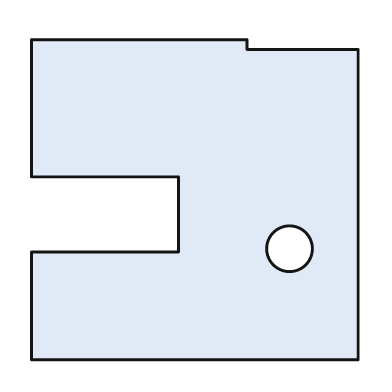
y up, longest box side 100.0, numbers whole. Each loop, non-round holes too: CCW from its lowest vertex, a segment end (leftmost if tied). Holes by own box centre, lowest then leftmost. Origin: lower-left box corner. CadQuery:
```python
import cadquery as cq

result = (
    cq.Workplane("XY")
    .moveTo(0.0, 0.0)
    .lineTo(100.0, 0.0)
    .lineTo(100.0, 95.0)
    .lineTo(66.0, 95.0)
    .lineTo(66.0, 98.0)
    .lineTo(0.0, 98.0)
    .lineTo(0.0, 56.0)
    .lineTo(45.0, 56.0)
    .lineTo(45.0, 33.0)
    .lineTo(0.0, 33.0)
    .close()
    .moveTo(79.0, 34.0)
    .circle(7.0)
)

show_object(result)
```